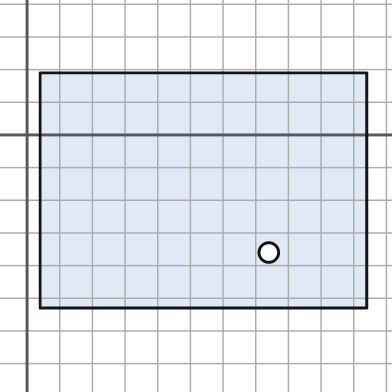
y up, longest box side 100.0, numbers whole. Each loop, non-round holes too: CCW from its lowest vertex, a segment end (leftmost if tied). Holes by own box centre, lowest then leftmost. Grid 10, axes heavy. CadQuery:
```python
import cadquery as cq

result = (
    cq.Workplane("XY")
    .moveTo(4.0, -53.0)
    .lineTo(104.0, -53.0)
    .lineTo(104.0, 19.0)
    .lineTo(4.0, 19.0)
    .close()
    .moveTo(74.0, -36.0)
    .circle(3.0)
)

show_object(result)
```